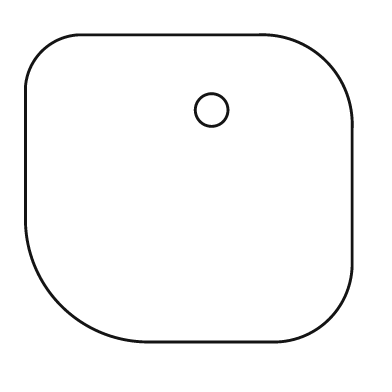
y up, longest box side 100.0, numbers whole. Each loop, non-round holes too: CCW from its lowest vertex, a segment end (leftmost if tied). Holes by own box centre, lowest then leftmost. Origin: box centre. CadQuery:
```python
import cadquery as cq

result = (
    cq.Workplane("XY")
    .moveTo(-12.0, -47.0)
    .lineTo(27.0, -47.0)
    .threePointArc((43.0, -40.0), (50.0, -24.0))
    .lineTo(50.0, 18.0)
    .threePointArc((42.0, 39.0), (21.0, 47.0))
    .lineTo(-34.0, 47.0)
    .threePointArc((-45.0, 42.0), (-50.0, 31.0))
    .lineTo(-50.0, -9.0)
    .threePointArc((-39.0, -36.0), (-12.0, -47.0))
    .close()
    .moveTo(7.0, 24.0)
    .circle(5.0)
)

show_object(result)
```